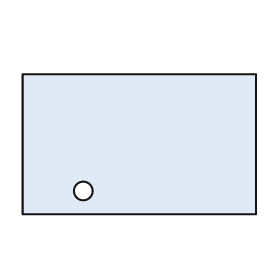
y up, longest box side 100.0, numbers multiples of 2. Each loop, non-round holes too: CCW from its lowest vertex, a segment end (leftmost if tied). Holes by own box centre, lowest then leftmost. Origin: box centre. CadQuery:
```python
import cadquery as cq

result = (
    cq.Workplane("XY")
    .moveTo(-50.0, -30.0)
    .lineTo(50.0, -30.0)
    .lineTo(50.0, 30.0)
    .lineTo(-50.0, 30.0)
    .close()
    .moveTo(-24.0, -20.0)
    .circle(4.0)
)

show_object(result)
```